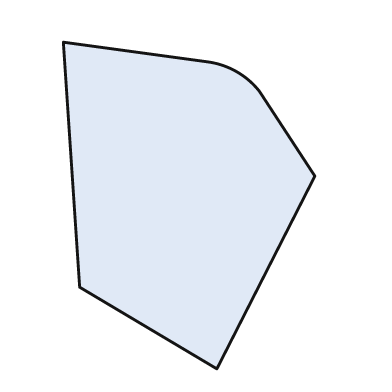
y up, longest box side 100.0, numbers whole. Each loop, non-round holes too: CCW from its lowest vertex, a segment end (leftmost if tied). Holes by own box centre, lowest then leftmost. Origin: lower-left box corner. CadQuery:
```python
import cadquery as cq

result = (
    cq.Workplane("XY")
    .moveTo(47.0, 0.0)
    .lineTo(77.0, 59.0)
    .lineTo(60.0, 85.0)
    .threePointArc((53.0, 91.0), (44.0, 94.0))
    .lineTo(0.0, 100.0)
    .lineTo(5.0, 25.0)
    .close()
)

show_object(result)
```